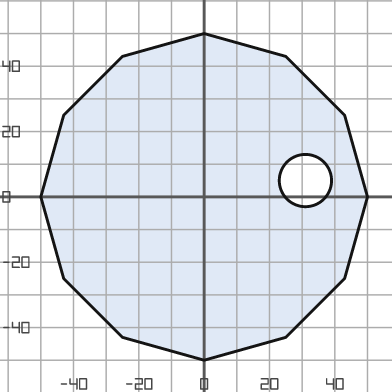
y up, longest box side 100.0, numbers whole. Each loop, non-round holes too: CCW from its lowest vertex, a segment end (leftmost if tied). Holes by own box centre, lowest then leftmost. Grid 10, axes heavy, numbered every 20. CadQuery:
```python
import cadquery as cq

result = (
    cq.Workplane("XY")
    .moveTo(0.0, -50.0)
    .lineTo(25.0, -43.0)
    .lineTo(43.0, -25.0)
    .lineTo(50.0, 0.0)
    .lineTo(43.0, 25.0)
    .lineTo(25.0, 43.0)
    .lineTo(0.0, 50.0)
    .lineTo(-25.0, 43.0)
    .lineTo(-43.0, 25.0)
    .lineTo(-50.0, 0.0)
    .lineTo(-43.0, -25.0)
    .lineTo(-25.0, -43.0)
    .close()
    .moveTo(31.0, 5.0)
    .circle(8.0)
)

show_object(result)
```